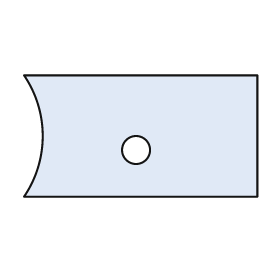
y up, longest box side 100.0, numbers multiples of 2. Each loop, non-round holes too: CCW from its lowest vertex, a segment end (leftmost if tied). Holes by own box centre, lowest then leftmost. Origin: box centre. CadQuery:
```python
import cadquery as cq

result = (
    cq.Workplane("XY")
    .moveTo(-50.0, -26.0)
    .lineTo(50.0, -26.0)
    .lineTo(50.0, 26.0)
    .lineTo(-50.0, 26.0)
    .threePointArc((-42.0, 0.0), (-50.0, -26.0))
    .close()
    .moveTo(-2.0, -6.0)
    .circle(6.0)
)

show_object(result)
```